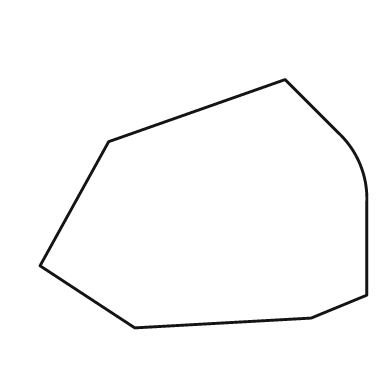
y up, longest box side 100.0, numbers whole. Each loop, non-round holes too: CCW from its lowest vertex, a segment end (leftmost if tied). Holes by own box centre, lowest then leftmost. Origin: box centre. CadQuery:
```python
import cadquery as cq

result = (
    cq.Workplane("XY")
    .moveTo(-21.0, -38.0)
    .lineTo(33.0, -35.0)
    .lineTo(50.0, -28.0)
    .lineTo(50.0, 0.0)
    .threePointArc((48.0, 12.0), (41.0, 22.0))
    .lineTo(25.0, 38.0)
    .lineTo(-29.0, 19.0)
    .lineTo(-50.0, -19.0)
    .close()
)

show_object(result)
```